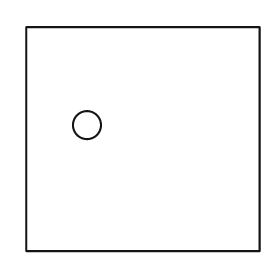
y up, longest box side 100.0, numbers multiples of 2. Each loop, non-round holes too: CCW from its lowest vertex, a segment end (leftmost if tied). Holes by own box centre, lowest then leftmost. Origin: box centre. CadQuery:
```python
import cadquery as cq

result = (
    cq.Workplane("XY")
    .moveTo(-50.0, -48.0)
    .lineTo(50.0, -48.0)
    .lineTo(50.0, 48.0)
    .lineTo(-50.0, 48.0)
    .close()
    .moveTo(-24.0, 6.0)
    .circle(6.0)
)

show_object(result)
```